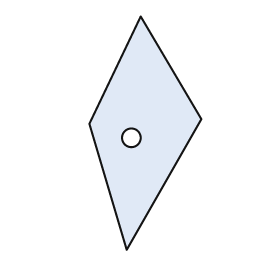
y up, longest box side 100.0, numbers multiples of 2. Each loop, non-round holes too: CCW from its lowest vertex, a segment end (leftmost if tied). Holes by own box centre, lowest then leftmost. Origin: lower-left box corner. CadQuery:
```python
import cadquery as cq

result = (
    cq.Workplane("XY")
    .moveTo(16.0, 0.0)
    .lineTo(48.0, 56.0)
    .lineTo(22.0, 100.0)
    .lineTo(0.0, 54.0)
    .close()
    .moveTo(18.0, 48.0)
    .circle(4.0)
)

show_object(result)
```